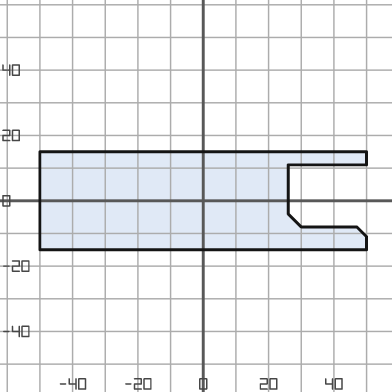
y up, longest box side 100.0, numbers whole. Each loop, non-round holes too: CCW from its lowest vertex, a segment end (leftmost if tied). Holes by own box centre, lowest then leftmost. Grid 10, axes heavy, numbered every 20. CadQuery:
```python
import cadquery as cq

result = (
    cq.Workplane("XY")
    .moveTo(-50.0, -15.0)
    .lineTo(50.0, -15.0)
    .lineTo(50.0, -11.0)
    .lineTo(47.0, -8.0)
    .lineTo(30.0, -8.0)
    .lineTo(26.0, -4.0)
    .lineTo(26.0, 11.0)
    .lineTo(50.0, 11.0)
    .lineTo(50.0, 15.0)
    .lineTo(-50.0, 15.0)
    .close()
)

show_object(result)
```